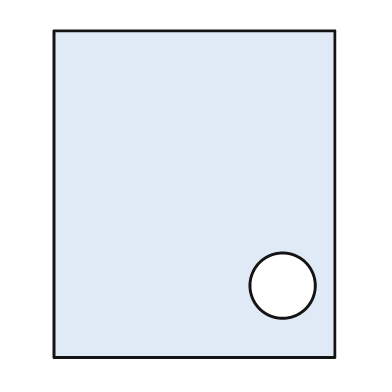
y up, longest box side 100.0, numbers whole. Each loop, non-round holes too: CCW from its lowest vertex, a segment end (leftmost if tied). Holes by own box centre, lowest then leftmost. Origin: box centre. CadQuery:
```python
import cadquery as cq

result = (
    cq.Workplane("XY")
    .moveTo(-43.0, -50.0)
    .lineTo(43.0, -50.0)
    .lineTo(43.0, 50.0)
    .lineTo(-43.0, 50.0)
    .close()
    .moveTo(27.0, -28.0)
    .circle(10.0)
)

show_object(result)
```